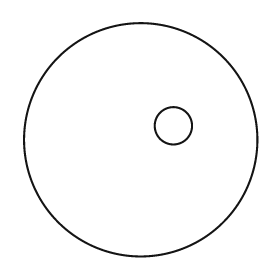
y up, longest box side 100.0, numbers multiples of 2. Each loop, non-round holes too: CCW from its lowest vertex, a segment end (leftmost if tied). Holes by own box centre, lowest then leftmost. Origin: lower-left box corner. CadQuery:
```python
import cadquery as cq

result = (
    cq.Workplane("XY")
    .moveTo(50.0, 50.0)
    .circle(50.0)
    .moveTo(64.0, 56.0)
    .circle(8.0)
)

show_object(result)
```